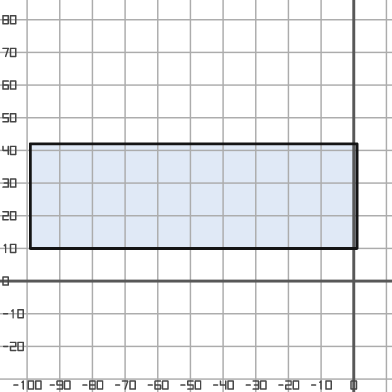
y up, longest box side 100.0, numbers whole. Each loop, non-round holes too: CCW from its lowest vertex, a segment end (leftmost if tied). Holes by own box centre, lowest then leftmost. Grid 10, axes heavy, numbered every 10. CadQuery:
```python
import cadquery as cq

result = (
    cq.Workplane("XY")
    .moveTo(-99.0, 10.0)
    .lineTo(1.0, 10.0)
    .lineTo(1.0, 42.0)
    .lineTo(-99.0, 42.0)
    .close()
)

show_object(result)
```